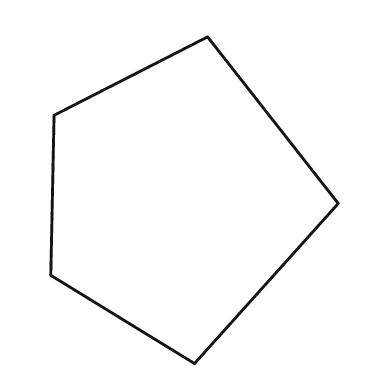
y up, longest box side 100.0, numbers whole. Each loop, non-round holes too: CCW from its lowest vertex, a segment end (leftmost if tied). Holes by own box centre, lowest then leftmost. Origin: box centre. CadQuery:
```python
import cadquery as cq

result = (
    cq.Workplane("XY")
    .moveTo(0.0, -50.0)
    .lineTo(44.0, -1.0)
    .lineTo(4.0, 50.0)
    .lineTo(-43.0, 26.0)
    .lineTo(-44.0, -23.0)
    .close()
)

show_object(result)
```